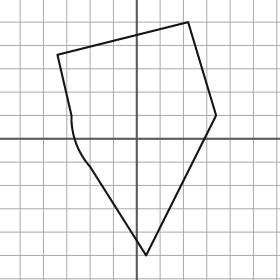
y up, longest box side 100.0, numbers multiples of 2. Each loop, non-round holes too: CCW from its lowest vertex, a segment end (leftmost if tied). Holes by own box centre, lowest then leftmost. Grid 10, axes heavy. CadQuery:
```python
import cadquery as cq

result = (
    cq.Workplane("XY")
    .moveTo(4.0, -50.0)
    .lineTo(34.0, 10.0)
    .lineTo(22.0, 50.0)
    .lineTo(-34.0, 36.0)
    .lineTo(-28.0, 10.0)
    .threePointArc((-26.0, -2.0), (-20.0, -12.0))
    .close()
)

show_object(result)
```